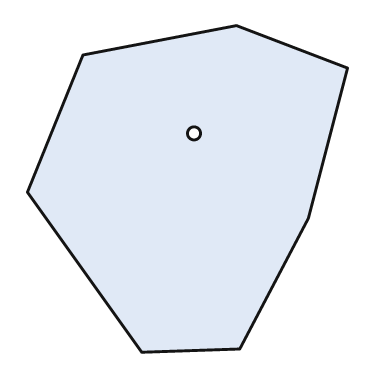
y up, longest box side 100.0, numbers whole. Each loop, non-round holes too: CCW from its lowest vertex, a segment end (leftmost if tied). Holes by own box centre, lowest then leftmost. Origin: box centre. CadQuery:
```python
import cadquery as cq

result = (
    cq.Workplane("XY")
    .moveTo(-14.0, -50.0)
    .lineTo(16.0, -49.0)
    .lineTo(37.0, -9.0)
    .lineTo(49.0, 37.0)
    .lineTo(15.0, 50.0)
    .lineTo(-32.0, 41.0)
    .lineTo(-49.0, -1.0)
    .close()
    .moveTo(2.0, 17.0)
    .circle(2.0)
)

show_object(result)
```